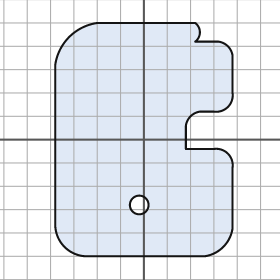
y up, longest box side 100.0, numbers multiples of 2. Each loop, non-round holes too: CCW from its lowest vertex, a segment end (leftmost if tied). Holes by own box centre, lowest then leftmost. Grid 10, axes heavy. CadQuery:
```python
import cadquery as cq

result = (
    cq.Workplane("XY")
    .moveTo(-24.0, -50.0)
    .lineTo(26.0, -50.0)
    .threePointArc((34.0, -46.0), (38.0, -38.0))
    .lineTo(38.0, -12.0)
    .threePointArc((36.0, -6.0), (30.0, -4.0))
    .lineTo(18.0, -4.0)
    .lineTo(18.0, 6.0)
    .threePointArc((20.0, 10.0), (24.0, 12.0))
    .lineTo(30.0, 12.0)
    .threePointArc((36.0, 14.0), (38.0, 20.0))
    .lineTo(38.0, 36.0)
    .threePointArc((36.0, 40.0), (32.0, 42.0))
    .lineTo(22.0, 42.0)
    .threePointArc((24.0, 46.0), (22.0, 50.0))
    .lineTo(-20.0, 50.0)
    .threePointArc((-32.0, 44.0), (-38.0, 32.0))
    .lineTo(-38.0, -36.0)
    .threePointArc((-34.0, -46.0), (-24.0, -50.0))
    .close()
    .moveTo(-2.0, -28.0)
    .circle(4.0)
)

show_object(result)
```